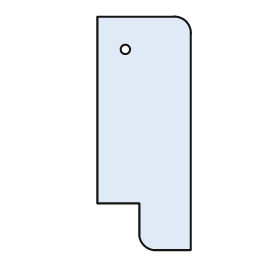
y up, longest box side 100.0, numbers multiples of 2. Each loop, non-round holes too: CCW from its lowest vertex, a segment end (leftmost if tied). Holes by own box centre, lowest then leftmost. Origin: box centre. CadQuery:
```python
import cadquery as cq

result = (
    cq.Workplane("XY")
    .moveTo(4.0, -50.0)
    .lineTo(20.0, -50.0)
    .lineTo(20.0, 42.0)
    .threePointArc((18.0, 48.0), (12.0, 50.0))
    .lineTo(-20.0, 50.0)
    .lineTo(-20.0, -30.0)
    .lineTo(-2.0, -30.0)
    .lineTo(-2.0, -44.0)
    .threePointArc((0.0, -48.0), (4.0, -50.0))
    .close()
    .moveTo(-8.0, 36.0)
    .circle(2.0)
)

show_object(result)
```